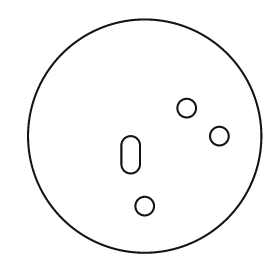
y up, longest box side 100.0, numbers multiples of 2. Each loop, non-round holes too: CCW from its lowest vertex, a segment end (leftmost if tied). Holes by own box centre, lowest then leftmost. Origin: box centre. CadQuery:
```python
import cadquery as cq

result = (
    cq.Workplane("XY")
    .moveTo(0.0, 0.0)
    .circle(50.0)
    .moveTo(0.0, -30.0)
    .circle(4.0)
    .moveTo(-10.0, -12.0)
    .threePointArc((-6.0, -16.0), (-2.0, -12.0))
    .lineTo(-2.0, -4.0)
    .threePointArc((-6.0, 0.0), (-10.0, -4.0))
    .close()
    .moveTo(32.0, 0.0)
    .circle(4.0)
    .moveTo(18.0, 12.0)
    .circle(4.0)
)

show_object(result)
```